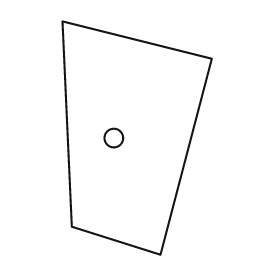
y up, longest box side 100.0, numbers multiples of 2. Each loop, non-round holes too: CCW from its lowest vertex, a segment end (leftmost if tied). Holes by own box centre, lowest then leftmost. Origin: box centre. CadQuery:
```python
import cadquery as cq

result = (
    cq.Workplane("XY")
    .moveTo(10.0, -50.0)
    .lineTo(32.0, 34.0)
    .lineTo(-32.0, 50.0)
    .lineTo(-28.0, -38.0)
    .close()
    .moveTo(-10.0, 0.0)
    .circle(4.0)
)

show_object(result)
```